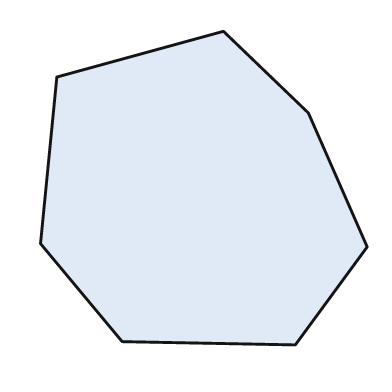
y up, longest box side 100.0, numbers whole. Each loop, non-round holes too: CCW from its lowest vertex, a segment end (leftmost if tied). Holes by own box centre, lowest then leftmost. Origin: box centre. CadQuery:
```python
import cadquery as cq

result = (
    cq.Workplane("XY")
    .moveTo(28.0, -48.0)
    .lineTo(50.0, -18.0)
    .lineTo(32.0, 23.0)
    .lineTo(6.0, 48.0)
    .lineTo(-45.0, 34.0)
    .lineTo(-50.0, -17.0)
    .lineTo(-25.0, -47.0)
    .close()
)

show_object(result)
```